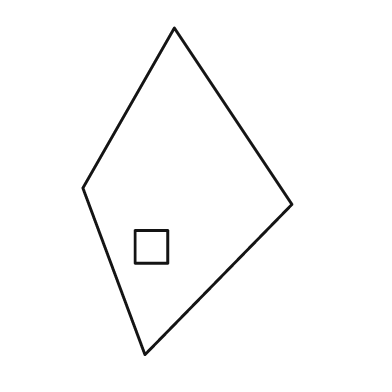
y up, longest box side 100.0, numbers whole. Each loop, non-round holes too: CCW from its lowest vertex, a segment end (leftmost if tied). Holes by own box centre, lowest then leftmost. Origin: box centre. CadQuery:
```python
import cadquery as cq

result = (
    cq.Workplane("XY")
    .moveTo(-13.0, -50.0)
    .lineTo(32.0, -4.0)
    .lineTo(-4.0, 50.0)
    .lineTo(-32.0, 1.0)
    .close()
    .moveTo(-16.0, -22.0)
    .lineTo(-6.0, -22.0)
    .lineTo(-6.0, -12.0)
    .lineTo(-16.0, -12.0)
    .close()
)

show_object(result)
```